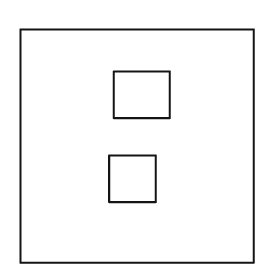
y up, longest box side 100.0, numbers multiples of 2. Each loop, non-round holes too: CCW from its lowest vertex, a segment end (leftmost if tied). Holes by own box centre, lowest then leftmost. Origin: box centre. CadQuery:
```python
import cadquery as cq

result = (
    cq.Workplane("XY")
    .moveTo(-50.0, -50.0)
    .lineTo(50.0, -50.0)
    .lineTo(50.0, 50.0)
    .lineTo(-50.0, 50.0)
    .close()
    .moveTo(-12.0, -24.0)
    .lineTo(8.0, -24.0)
    .lineTo(8.0, -4.0)
    .lineTo(-12.0, -4.0)
    .close()
    .moveTo(-10.0, 12.0)
    .lineTo(14.0, 12.0)
    .lineTo(14.0, 32.0)
    .lineTo(-10.0, 32.0)
    .close()
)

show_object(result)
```